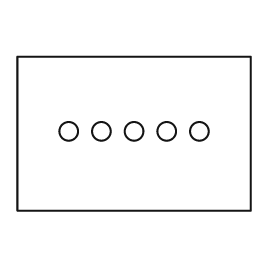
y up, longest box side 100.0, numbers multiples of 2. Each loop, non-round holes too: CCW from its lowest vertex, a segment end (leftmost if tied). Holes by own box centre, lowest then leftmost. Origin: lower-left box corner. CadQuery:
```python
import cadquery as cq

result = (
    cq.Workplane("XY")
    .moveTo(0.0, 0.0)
    .lineTo(100.0, 0.0)
    .lineTo(100.0, 66.0)
    .lineTo(0.0, 66.0)
    .close()
    .moveTo(22.0, 34.0)
    .circle(4.0)
    .moveTo(36.0, 34.0)
    .circle(4.0)
    .moveTo(50.0, 34.0)
    .circle(4.0)
    .moveTo(64.0, 34.0)
    .circle(4.0)
    .moveTo(78.0, 34.0)
    .circle(4.0)
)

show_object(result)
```